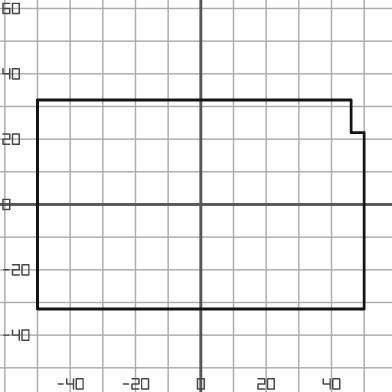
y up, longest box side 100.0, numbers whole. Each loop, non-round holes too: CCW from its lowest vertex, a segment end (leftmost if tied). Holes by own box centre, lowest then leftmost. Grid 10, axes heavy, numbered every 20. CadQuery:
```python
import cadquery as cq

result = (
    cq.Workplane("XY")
    .moveTo(-50.0, -32.0)
    .lineTo(50.0, -32.0)
    .lineTo(50.0, 22.0)
    .lineTo(46.0, 22.0)
    .lineTo(46.0, 32.0)
    .lineTo(-50.0, 32.0)
    .close()
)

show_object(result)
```